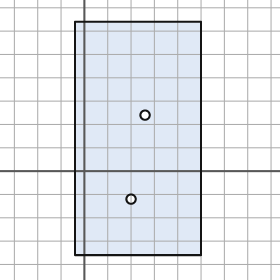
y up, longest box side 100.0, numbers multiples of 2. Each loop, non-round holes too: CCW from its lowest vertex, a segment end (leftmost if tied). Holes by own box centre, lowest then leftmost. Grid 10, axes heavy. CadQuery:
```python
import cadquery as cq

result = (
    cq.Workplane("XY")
    .moveTo(-4.0, -36.0)
    .lineTo(50.0, -36.0)
    .lineTo(50.0, 64.0)
    .lineTo(-4.0, 64.0)
    .close()
    .moveTo(20.0, -12.0)
    .circle(2.0)
    .moveTo(26.0, 24.0)
    .circle(2.0)
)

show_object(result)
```